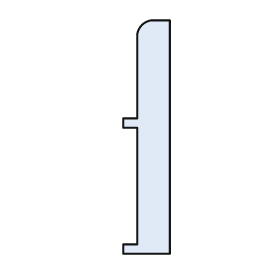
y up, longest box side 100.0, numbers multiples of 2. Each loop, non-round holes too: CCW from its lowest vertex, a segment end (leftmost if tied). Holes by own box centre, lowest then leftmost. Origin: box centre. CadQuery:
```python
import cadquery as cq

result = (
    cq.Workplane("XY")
    .moveTo(-10.0, -50.0)
    .lineTo(10.0, -50.0)
    .lineTo(10.0, 50.0)
    .lineTo(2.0, 50.0)
    .threePointArc((-2.0, 48.0), (-4.0, 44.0))
    .lineTo(-4.0, 8.0)
    .lineTo(-10.0, 8.0)
    .lineTo(-10.0, 4.0)
    .lineTo(-4.0, 4.0)
    .lineTo(-4.0, -46.0)
    .lineTo(-10.0, -46.0)
    .close()
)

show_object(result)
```